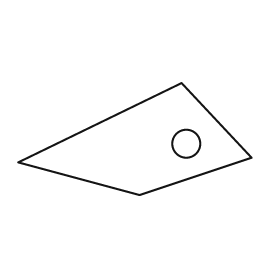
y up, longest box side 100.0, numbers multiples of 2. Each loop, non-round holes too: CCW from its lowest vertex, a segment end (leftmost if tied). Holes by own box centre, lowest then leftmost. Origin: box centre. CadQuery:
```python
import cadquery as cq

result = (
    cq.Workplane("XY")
    .moveTo(2.0, -24.0)
    .lineTo(50.0, -8.0)
    .lineTo(20.0, 24.0)
    .lineTo(-50.0, -10.0)
    .close()
    .moveTo(22.0, -2.0)
    .circle(6.0)
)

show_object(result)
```